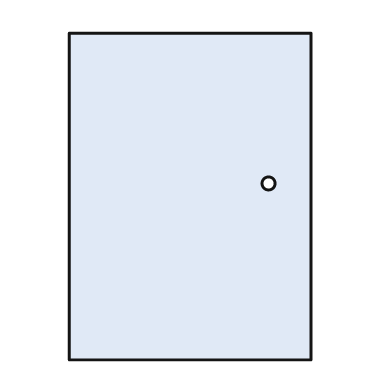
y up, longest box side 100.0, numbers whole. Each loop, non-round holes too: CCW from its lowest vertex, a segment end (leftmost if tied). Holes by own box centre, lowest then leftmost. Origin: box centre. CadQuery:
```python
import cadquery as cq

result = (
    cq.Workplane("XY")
    .moveTo(-37.0, -50.0)
    .lineTo(37.0, -50.0)
    .lineTo(37.0, 50.0)
    .lineTo(-37.0, 50.0)
    .close()
    .moveTo(24.0, 4.0)
    .circle(2.0)
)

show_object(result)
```